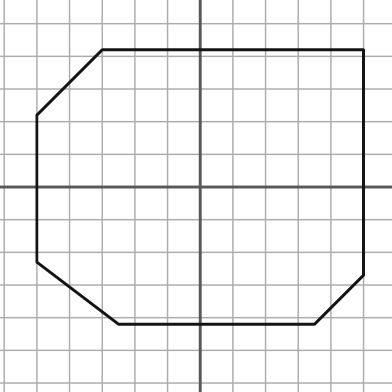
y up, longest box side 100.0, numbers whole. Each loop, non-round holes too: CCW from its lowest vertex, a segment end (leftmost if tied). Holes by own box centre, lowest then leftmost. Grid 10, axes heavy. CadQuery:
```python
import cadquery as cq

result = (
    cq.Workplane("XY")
    .moveTo(-25.0, -42.0)
    .lineTo(35.0, -42.0)
    .lineTo(50.0, -27.0)
    .lineTo(50.0, 42.0)
    .lineTo(-30.0, 42.0)
    .lineTo(-50.0, 22.0)
    .lineTo(-50.0, -23.0)
    .close()
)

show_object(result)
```